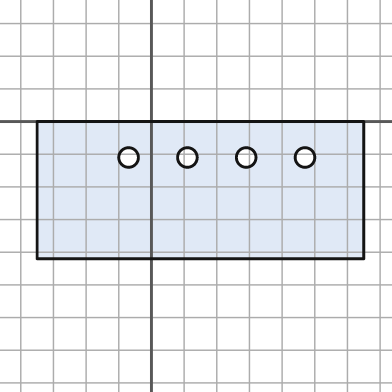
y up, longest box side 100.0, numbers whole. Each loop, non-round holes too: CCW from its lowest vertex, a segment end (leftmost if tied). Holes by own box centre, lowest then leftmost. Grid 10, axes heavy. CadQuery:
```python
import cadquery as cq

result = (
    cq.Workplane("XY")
    .moveTo(-35.0, -42.0)
    .lineTo(65.0, -42.0)
    .lineTo(65.0, 0.0)
    .lineTo(-35.0, 0.0)
    .close()
    .moveTo(-7.0, -11.0)
    .circle(3.0)
    .moveTo(11.0, -11.0)
    .circle(3.0)
    .moveTo(29.0, -11.0)
    .circle(3.0)
    .moveTo(47.0, -11.0)
    .circle(3.0)
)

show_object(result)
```